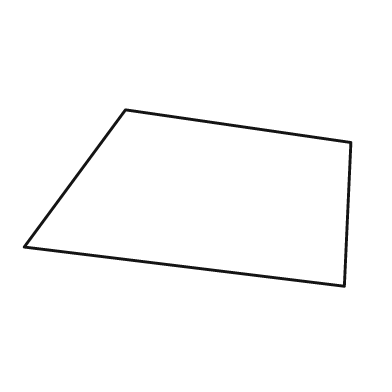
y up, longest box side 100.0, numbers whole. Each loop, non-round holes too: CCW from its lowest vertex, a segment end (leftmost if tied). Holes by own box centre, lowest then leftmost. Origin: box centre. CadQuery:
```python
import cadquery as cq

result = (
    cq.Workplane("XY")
    .moveTo(48.0, -27.0)
    .lineTo(50.0, 17.0)
    .lineTo(-19.0, 27.0)
    .lineTo(-50.0, -15.0)
    .close()
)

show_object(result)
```